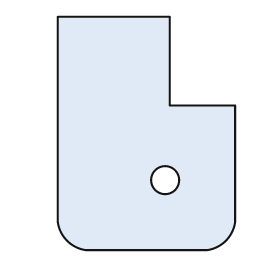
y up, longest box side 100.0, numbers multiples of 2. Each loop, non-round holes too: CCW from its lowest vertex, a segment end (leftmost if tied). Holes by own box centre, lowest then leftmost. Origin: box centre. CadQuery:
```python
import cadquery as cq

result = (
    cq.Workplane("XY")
    .moveTo(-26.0, -50.0)
    .lineTo(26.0, -50.0)
    .threePointArc((34.0, -46.0), (38.0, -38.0))
    .lineTo(38.0, 12.0)
    .lineTo(10.0, 12.0)
    .lineTo(10.0, 50.0)
    .lineTo(-38.0, 50.0)
    .lineTo(-38.0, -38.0)
    .threePointArc((-34.0, -46.0), (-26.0, -50.0))
    .close()
    .moveTo(8.0, -20.0)
    .circle(6.0)
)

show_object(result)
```